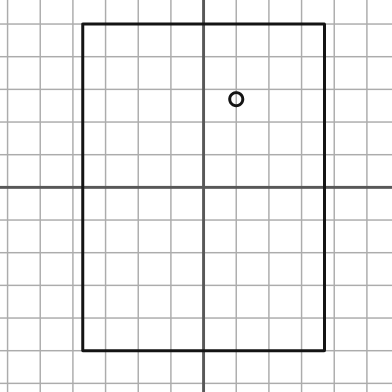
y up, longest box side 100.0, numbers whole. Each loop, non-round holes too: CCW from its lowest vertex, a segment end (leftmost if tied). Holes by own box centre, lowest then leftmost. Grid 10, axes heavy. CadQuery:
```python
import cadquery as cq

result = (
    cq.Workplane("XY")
    .moveTo(-37.0, -50.0)
    .lineTo(37.0, -50.0)
    .lineTo(37.0, 50.0)
    .lineTo(-37.0, 50.0)
    .close()
    .moveTo(10.0, 27.0)
    .circle(2.0)
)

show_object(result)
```